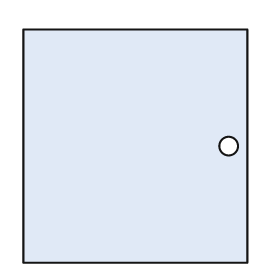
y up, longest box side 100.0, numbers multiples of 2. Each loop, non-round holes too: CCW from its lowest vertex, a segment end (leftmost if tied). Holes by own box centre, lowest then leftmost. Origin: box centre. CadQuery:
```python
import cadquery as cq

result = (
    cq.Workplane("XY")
    .moveTo(-48.0, -50.0)
    .lineTo(48.0, -50.0)
    .lineTo(48.0, 50.0)
    .lineTo(-48.0, 50.0)
    .close()
    .moveTo(40.0, 0.0)
    .circle(4.0)
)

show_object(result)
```